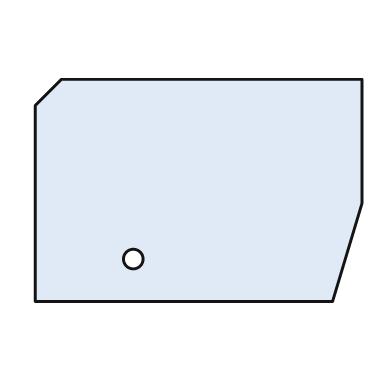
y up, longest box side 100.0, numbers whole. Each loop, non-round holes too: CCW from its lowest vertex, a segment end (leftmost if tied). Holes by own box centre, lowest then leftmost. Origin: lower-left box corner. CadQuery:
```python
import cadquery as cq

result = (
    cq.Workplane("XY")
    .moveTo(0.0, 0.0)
    .lineTo(91.0, 0.0)
    .lineTo(100.0, 30.0)
    .lineTo(100.0, 68.0)
    .lineTo(8.0, 68.0)
    .lineTo(0.0, 60.0)
    .close()
    .moveTo(30.0, 13.0)
    .circle(3.0)
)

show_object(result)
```